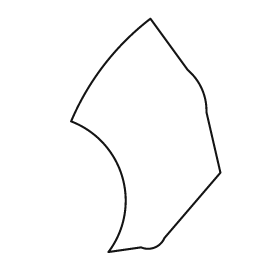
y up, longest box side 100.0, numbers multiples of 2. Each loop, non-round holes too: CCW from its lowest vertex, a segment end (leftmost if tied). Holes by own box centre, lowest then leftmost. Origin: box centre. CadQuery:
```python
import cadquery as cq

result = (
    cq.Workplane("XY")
    .moveTo(-16.0, -50.0)
    .lineTo(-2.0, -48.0)
    .threePointArc((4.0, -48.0), (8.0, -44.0))
    .lineTo(32.0, -16.0)
    .lineTo(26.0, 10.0)
    .threePointArc((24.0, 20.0), (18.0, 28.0))
    .lineTo(2.0, 50.0)
    .threePointArc((-18.0, 30.0), (-32.0, 6.0))
    .threePointArc((-10.0, -18.0), (-16.0, -50.0))
    .close()
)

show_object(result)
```